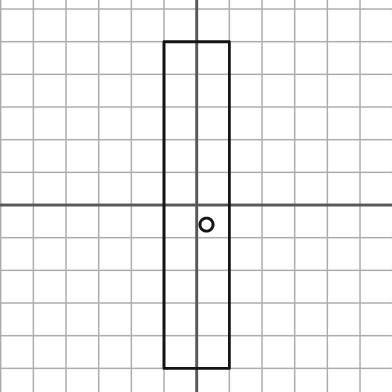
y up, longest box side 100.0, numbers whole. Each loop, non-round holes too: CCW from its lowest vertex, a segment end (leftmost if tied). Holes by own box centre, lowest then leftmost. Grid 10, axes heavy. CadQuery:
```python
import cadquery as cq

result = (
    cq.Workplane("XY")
    .moveTo(-10.0, -50.0)
    .lineTo(10.0, -50.0)
    .lineTo(10.0, 50.0)
    .lineTo(-10.0, 50.0)
    .close()
    .moveTo(3.0, -6.0)
    .circle(2.0)
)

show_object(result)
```